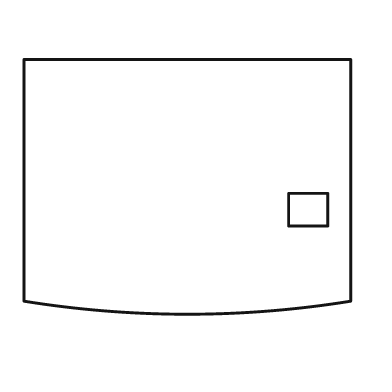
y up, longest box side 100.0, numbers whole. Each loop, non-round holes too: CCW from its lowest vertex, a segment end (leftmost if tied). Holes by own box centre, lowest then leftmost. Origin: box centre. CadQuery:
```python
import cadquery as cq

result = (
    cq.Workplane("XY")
    .moveTo(-50.0, -35.0)
    .threePointArc((0.0, -39.0), (50.0, -35.0))
    .lineTo(50.0, 39.0)
    .lineTo(-50.0, 39.0)
    .close()
    .moveTo(31.0, -12.0)
    .lineTo(43.0, -12.0)
    .lineTo(43.0, -2.0)
    .lineTo(31.0, -2.0)
    .close()
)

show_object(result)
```